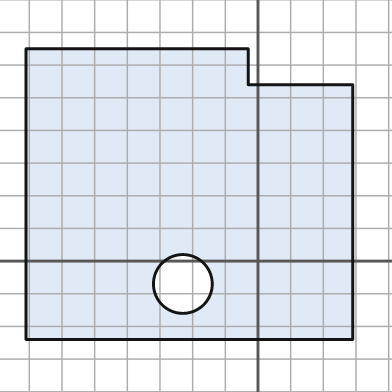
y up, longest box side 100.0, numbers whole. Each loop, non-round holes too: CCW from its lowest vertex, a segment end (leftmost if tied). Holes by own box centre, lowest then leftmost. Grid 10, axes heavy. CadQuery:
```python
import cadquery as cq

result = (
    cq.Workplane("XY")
    .moveTo(-71.0, -24.0)
    .lineTo(29.0, -24.0)
    .lineTo(29.0, 54.0)
    .lineTo(-3.0, 54.0)
    .lineTo(-3.0, 65.0)
    .lineTo(-71.0, 65.0)
    .close()
    .moveTo(-23.0, -7.0)
    .circle(9.0)
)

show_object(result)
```